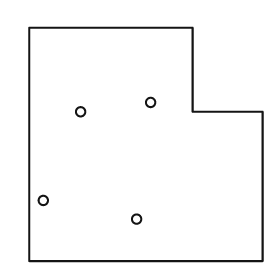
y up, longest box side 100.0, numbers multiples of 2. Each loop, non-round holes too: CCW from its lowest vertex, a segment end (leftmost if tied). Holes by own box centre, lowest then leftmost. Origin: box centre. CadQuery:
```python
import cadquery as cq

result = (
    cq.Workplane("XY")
    .moveTo(-50.0, -50.0)
    .lineTo(50.0, -50.0)
    .lineTo(50.0, 14.0)
    .lineTo(20.0, 14.0)
    .lineTo(20.0, 50.0)
    .lineTo(-50.0, 50.0)
    .close()
    .moveTo(-4.0, -32.0)
    .circle(2.0)
    .moveTo(-44.0, -24.0)
    .circle(2.0)
    .moveTo(-28.0, 14.0)
    .circle(2.0)
    .moveTo(2.0, 18.0)
    .circle(2.0)
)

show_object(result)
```